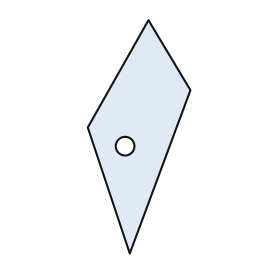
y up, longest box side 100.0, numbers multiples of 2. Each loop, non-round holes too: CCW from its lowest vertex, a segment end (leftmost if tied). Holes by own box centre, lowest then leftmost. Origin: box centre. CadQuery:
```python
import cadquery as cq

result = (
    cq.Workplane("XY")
    .moveTo(-4.0, -50.0)
    .lineTo(22.0, 20.0)
    .lineTo(4.0, 50.0)
    .lineTo(-22.0, 4.0)
    .close()
    .moveTo(-6.0, -4.0)
    .circle(4.0)
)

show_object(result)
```